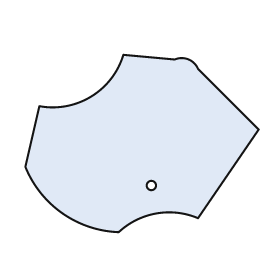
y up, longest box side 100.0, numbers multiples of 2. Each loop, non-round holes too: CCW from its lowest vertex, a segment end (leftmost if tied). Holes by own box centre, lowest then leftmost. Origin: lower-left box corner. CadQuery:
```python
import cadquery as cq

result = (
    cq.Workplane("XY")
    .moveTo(40.0, 0.0)
    .threePointArc((56.0, 8.0), (74.0, 6.0))
    .lineTo(100.0, 44.0)
    .lineTo(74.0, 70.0)
    .threePointArc((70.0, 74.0), (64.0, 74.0))
    .lineTo(42.0, 76.0)
    .threePointArc((28.0, 58.0), (6.0, 54.0))
    .lineTo(0.0, 28.0)
    .threePointArc((16.0, 8.0), (40.0, 0.0))
    .close()
    .moveTo(54.0, 20.0)
    .circle(2.0)
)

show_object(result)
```